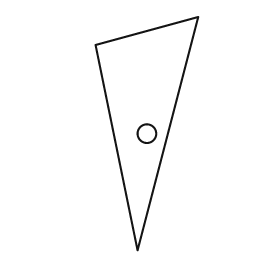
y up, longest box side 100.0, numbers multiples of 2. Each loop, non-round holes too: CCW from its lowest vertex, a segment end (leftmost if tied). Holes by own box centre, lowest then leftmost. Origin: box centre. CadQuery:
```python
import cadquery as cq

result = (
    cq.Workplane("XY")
    .moveTo(-4.0, -50.0)
    .lineTo(22.0, 50.0)
    .lineTo(-22.0, 38.0)
    .close()
    .moveTo(0.0, 0.0)
    .circle(4.0)
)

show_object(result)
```